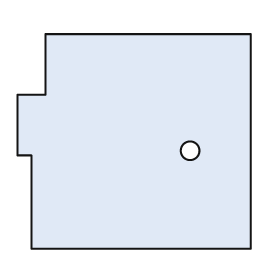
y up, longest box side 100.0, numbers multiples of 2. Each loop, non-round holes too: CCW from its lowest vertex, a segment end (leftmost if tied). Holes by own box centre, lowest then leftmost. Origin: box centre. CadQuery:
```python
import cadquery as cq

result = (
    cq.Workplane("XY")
    .moveTo(-44.0, -46.0)
    .lineTo(50.0, -46.0)
    .lineTo(50.0, 46.0)
    .lineTo(-38.0, 46.0)
    .lineTo(-38.0, 20.0)
    .lineTo(-50.0, 20.0)
    .lineTo(-50.0, -6.0)
    .lineTo(-44.0, -6.0)
    .close()
    .moveTo(24.0, -4.0)
    .circle(4.0)
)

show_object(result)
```